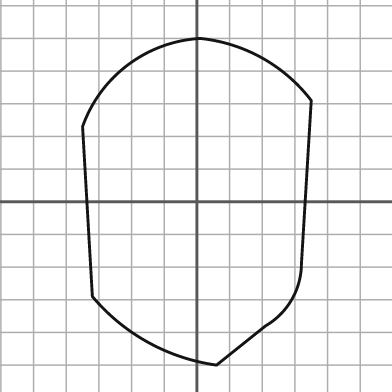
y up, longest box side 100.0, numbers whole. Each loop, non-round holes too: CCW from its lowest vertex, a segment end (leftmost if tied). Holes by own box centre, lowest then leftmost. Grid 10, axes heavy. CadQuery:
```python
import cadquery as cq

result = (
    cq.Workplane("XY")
    .moveTo(6.0, -50.0)
    .lineTo(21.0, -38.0)
    .threePointArc((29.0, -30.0), (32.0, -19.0))
    .lineTo(35.0, 31.0)
    .threePointArc((20.0, 44.0), (1.0, 50.0))
    .threePointArc((-21.0, 42.0), (-35.0, 23.0))
    .lineTo(-32.0, -29.0)
    .threePointArc((-15.0, -43.0), (6.0, -50.0))
    .close()
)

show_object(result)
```